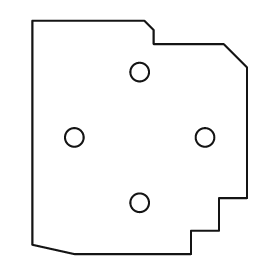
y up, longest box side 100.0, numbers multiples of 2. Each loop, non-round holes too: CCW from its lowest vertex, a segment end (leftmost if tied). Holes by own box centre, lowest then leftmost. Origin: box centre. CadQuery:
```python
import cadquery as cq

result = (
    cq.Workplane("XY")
    .moveTo(-28.0, -50.0)
    .lineTo(22.0, -50.0)
    .lineTo(22.0, -40.0)
    .lineTo(34.0, -40.0)
    .lineTo(34.0, -26.0)
    .lineTo(46.0, -26.0)
    .lineTo(46.0, 30.0)
    .lineTo(36.0, 40.0)
    .lineTo(6.0, 40.0)
    .lineTo(6.0, 46.0)
    .lineTo(2.0, 50.0)
    .lineTo(-46.0, 50.0)
    .lineTo(-46.0, -46.0)
    .close()
    .moveTo(0.0, -28.0)
    .circle(4.0)
    .moveTo(-28.0, 0.0)
    .circle(4.0)
    .moveTo(28.0, 0.0)
    .circle(4.0)
    .moveTo(0.0, 28.0)
    .circle(4.0)
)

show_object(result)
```